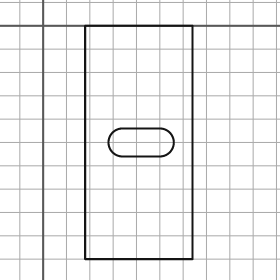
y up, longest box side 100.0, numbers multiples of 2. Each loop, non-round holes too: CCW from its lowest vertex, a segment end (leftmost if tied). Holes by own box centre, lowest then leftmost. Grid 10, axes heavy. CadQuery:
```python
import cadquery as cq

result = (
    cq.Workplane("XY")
    .moveTo(18.0, -100.0)
    .lineTo(64.0, -100.0)
    .lineTo(64.0, 0.0)
    .lineTo(18.0, 0.0)
    .close()
    .moveTo(34.0, -56.0)
    .lineTo(50.0, -56.0)
    .threePointArc((56.0, -50.0), (50.0, -44.0))
    .lineTo(34.0, -44.0)
    .threePointArc((28.0, -50.0), (34.0, -56.0))
    .close()
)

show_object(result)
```